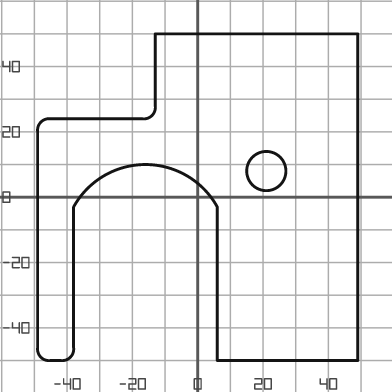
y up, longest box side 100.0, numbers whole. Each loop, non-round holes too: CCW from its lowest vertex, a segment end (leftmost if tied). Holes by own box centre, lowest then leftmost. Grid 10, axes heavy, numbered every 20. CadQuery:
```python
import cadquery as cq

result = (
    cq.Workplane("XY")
    .moveTo(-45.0, -50.0)
    .lineTo(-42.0, -50.0)
    .threePointArc((-39.0, -49.0), (-38.0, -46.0))
    .lineTo(-38.0, -3.0)
    .threePointArc((-16.0, 10.0), (6.0, -3.0))
    .lineTo(6.0, -50.0)
    .lineTo(49.0, -50.0)
    .lineTo(49.0, 50.0)
    .lineTo(-13.0, 50.0)
    .lineTo(-13.0, 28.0)
    .threePointArc((-14.0, 25.0), (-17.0, 24.0))
    .lineTo(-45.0, 24.0)
    .threePointArc((-48.0, 23.0), (-49.0, 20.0))
    .lineTo(-49.0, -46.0)
    .threePointArc((-48.0, -49.0), (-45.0, -50.0))
    .close()
    .moveTo(21.0, 8.0)
    .circle(6.0)
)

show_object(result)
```